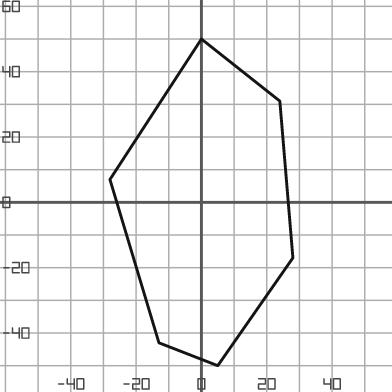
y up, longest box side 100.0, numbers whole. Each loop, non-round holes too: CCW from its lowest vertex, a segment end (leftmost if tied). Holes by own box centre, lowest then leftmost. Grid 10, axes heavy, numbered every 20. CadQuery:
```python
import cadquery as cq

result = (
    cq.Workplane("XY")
    .moveTo(5.0, -50.0)
    .lineTo(28.0, -17.0)
    .lineTo(24.0, 31.0)
    .lineTo(0.0, 50.0)
    .lineTo(-28.0, 7.0)
    .lineTo(-13.0, -43.0)
    .close()
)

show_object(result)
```